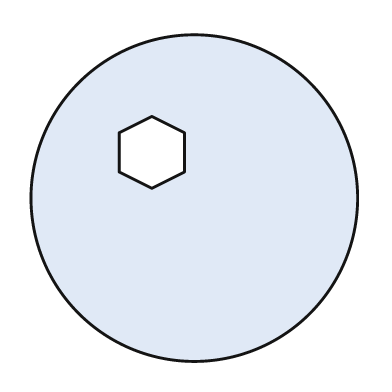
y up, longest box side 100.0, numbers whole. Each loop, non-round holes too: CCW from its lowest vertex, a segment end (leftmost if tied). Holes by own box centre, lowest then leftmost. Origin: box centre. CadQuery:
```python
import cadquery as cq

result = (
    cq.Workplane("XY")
    .moveTo(0.0, 0.0)
    .circle(50.0)
    .moveTo(-13.0, 3.0)
    .lineTo(-3.0, 8.0)
    .lineTo(-3.0, 20.0)
    .lineTo(-13.0, 25.0)
    .lineTo(-23.0, 20.0)
    .lineTo(-23.0, 8.0)
    .close()
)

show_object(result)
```